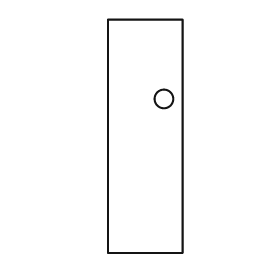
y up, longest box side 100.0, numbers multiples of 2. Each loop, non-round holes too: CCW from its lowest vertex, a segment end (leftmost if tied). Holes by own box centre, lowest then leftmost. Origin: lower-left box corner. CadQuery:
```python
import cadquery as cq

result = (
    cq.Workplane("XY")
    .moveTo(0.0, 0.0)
    .lineTo(32.0, 0.0)
    .lineTo(32.0, 100.0)
    .lineTo(0.0, 100.0)
    .close()
    .moveTo(24.0, 66.0)
    .circle(4.0)
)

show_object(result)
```